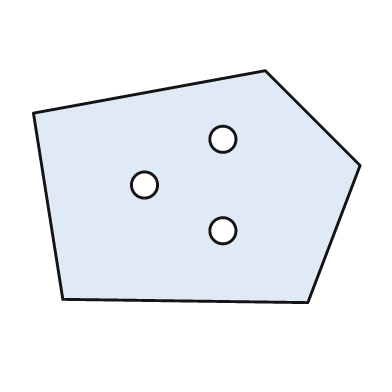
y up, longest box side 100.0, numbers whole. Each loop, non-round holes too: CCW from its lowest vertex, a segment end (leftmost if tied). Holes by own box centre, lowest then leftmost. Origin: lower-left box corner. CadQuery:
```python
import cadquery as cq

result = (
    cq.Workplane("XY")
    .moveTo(84.0, 0.0)
    .lineTo(100.0, 42.0)
    .lineTo(71.0, 71.0)
    .lineTo(0.0, 58.0)
    .lineTo(9.0, 1.0)
    .close()
    .moveTo(58.0, 22.0)
    .circle(4.0)
    .moveTo(34.0, 36.0)
    .circle(4.0)
    .moveTo(58.0, 50.0)
    .circle(4.0)
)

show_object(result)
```